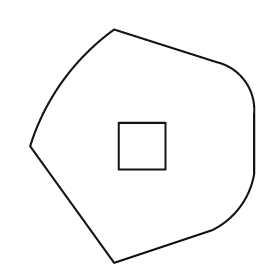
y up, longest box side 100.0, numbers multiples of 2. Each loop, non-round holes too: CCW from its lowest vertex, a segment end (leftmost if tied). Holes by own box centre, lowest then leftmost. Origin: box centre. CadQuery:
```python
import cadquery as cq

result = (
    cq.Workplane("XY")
    .moveTo(-12.0, -50.0)
    .lineTo(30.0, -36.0)
    .threePointArc((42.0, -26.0), (48.0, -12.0))
    .lineTo(48.0, 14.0)
    .threePointArc((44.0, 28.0), (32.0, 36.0))
    .lineTo(-12.0, 50.0)
    .threePointArc((-34.0, 28.0), (-48.0, 0.0))
    .close()
    .moveTo(-10.0, -10.0)
    .lineTo(10.0, -10.0)
    .lineTo(10.0, 10.0)
    .lineTo(-10.0, 10.0)
    .close()
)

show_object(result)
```